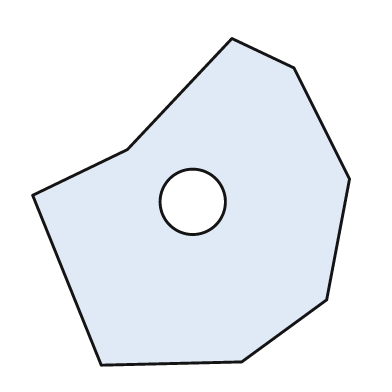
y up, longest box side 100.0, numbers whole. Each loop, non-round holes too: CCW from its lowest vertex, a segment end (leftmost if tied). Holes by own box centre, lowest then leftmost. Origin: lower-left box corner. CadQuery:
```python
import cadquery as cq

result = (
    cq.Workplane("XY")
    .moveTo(21.0, 0.0)
    .lineTo(64.0, 1.0)
    .lineTo(90.0, 20.0)
    .lineTo(97.0, 57.0)
    .lineTo(80.0, 91.0)
    .lineTo(61.0, 100.0)
    .lineTo(29.0, 66.0)
    .lineTo(0.0, 52.0)
    .close()
    .moveTo(49.0, 50.0)
    .circle(10.0)
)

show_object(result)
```